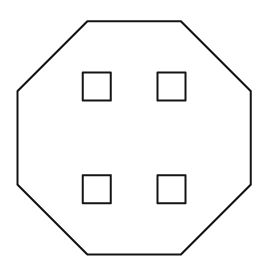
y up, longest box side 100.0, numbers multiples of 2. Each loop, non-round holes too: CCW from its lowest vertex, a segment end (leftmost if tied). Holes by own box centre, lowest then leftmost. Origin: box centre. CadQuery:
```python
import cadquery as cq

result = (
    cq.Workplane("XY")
    .moveTo(-20.0, -50.0)
    .lineTo(20.0, -50.0)
    .lineTo(50.0, -20.0)
    .lineTo(50.0, 20.0)
    .lineTo(20.0, 50.0)
    .lineTo(-20.0, 50.0)
    .lineTo(-50.0, 20.0)
    .lineTo(-50.0, -20.0)
    .close()
    .moveTo(-22.0, -28.0)
    .lineTo(-10.0, -28.0)
    .lineTo(-10.0, -16.0)
    .lineTo(-22.0, -16.0)
    .close()
    .moveTo(10.0, -28.0)
    .lineTo(22.0, -28.0)
    .lineTo(22.0, -16.0)
    .lineTo(10.0, -16.0)
    .close()
    .moveTo(-22.0, 16.0)
    .lineTo(-10.0, 16.0)
    .lineTo(-10.0, 28.0)
    .lineTo(-22.0, 28.0)
    .close()
    .moveTo(10.0, 16.0)
    .lineTo(22.0, 16.0)
    .lineTo(22.0, 28.0)
    .lineTo(10.0, 28.0)
    .close()
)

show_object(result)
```